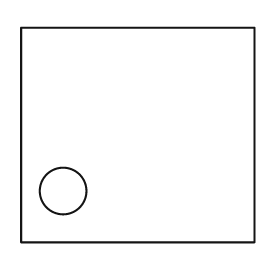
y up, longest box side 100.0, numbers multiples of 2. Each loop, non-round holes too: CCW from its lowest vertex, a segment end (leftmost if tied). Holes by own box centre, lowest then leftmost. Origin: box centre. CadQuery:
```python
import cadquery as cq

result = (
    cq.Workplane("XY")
    .moveTo(-50.0, -46.0)
    .lineTo(50.0, -46.0)
    .lineTo(50.0, 46.0)
    .lineTo(-50.0, 46.0)
    .close()
    .moveTo(-32.0, -24.0)
    .circle(10.0)
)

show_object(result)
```